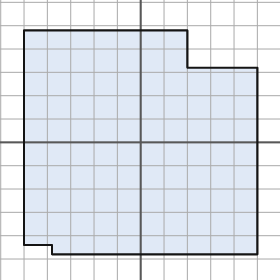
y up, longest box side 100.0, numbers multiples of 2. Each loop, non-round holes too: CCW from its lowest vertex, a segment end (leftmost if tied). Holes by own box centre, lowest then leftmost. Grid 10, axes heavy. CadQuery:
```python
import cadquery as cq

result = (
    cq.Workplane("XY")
    .moveTo(-38.0, -48.0)
    .lineTo(50.0, -48.0)
    .lineTo(50.0, 32.0)
    .lineTo(20.0, 32.0)
    .lineTo(20.0, 48.0)
    .lineTo(-50.0, 48.0)
    .lineTo(-50.0, -44.0)
    .lineTo(-38.0, -44.0)
    .close()
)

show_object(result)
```